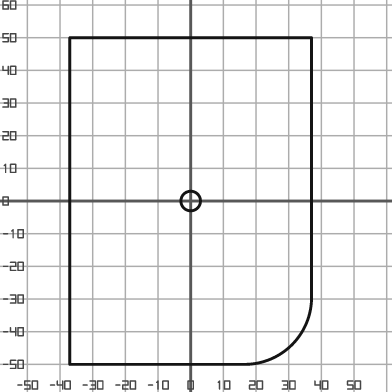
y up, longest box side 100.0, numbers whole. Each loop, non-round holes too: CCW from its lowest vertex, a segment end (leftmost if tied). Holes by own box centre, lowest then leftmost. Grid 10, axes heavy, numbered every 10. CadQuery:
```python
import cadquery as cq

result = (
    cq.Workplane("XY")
    .moveTo(-37.0, -50.0)
    .lineTo(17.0, -50.0)
    .threePointArc((31.0, -44.0), (37.0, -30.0))
    .lineTo(37.0, 50.0)
    .lineTo(-37.0, 50.0)
    .close()
    .moveTo(0.0, 0.0)
    .circle(3.0)
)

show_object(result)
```